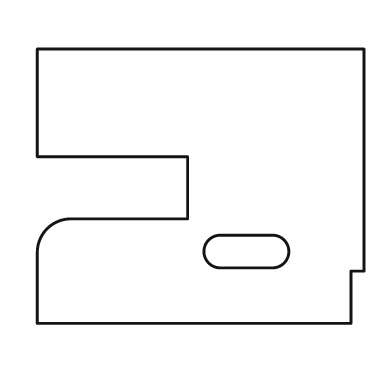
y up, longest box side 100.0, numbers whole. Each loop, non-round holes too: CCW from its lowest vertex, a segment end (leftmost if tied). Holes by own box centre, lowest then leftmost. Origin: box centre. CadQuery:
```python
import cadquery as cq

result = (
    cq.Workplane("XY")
    .moveTo(-50.0, -42.0)
    .lineTo(46.0, -42.0)
    .lineTo(46.0, -26.0)
    .lineTo(50.0, -26.0)
    .lineTo(50.0, 42.0)
    .lineTo(-50.0, 42.0)
    .lineTo(-50.0, 9.0)
    .lineTo(-4.0, 9.0)
    .lineTo(-4.0, -10.0)
    .lineTo(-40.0, -10.0)
    .threePointArc((-47.0, -13.0), (-50.0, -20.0))
    .close()
    .moveTo(6.0, -25.0)
    .lineTo(22.0, -25.0)
    .threePointArc((27.0, -20.0), (22.0, -15.0))
    .lineTo(6.0, -15.0)
    .threePointArc((1.0, -20.0), (6.0, -25.0))
    .close()
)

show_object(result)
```